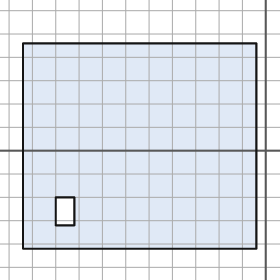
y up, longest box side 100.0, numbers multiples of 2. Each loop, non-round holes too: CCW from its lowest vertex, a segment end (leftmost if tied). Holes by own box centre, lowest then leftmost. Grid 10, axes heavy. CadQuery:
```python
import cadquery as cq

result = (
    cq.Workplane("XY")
    .moveTo(-104.0, -42.0)
    .lineTo(-4.0, -42.0)
    .lineTo(-4.0, 46.0)
    .lineTo(-104.0, 46.0)
    .close()
    .moveTo(-90.0, -32.0)
    .lineTo(-82.0, -32.0)
    .lineTo(-82.0, -20.0)
    .lineTo(-90.0, -20.0)
    .close()
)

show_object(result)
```